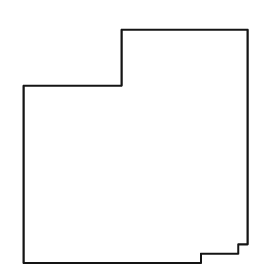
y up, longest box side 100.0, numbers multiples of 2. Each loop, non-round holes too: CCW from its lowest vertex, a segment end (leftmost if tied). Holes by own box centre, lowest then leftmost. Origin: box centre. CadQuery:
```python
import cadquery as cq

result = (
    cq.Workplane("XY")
    .moveTo(-48.0, -50.0)
    .lineTo(28.0, -50.0)
    .lineTo(28.0, -46.0)
    .lineTo(44.0, -46.0)
    .lineTo(44.0, -42.0)
    .lineTo(48.0, -42.0)
    .lineTo(48.0, 50.0)
    .lineTo(-6.0, 50.0)
    .lineTo(-6.0, 26.0)
    .lineTo(-48.0, 26.0)
    .close()
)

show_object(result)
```